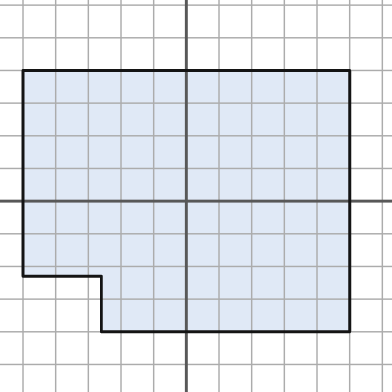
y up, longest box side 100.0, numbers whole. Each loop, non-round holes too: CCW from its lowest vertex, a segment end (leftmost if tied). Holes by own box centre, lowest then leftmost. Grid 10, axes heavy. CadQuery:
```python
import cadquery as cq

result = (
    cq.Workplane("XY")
    .moveTo(-26.0, -40.0)
    .lineTo(50.0, -40.0)
    .lineTo(50.0, 40.0)
    .lineTo(-50.0, 40.0)
    .lineTo(-50.0, -23.0)
    .lineTo(-26.0, -23.0)
    .close()
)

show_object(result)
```